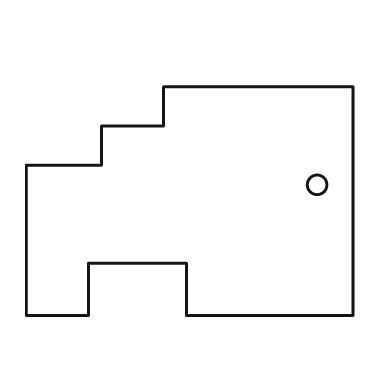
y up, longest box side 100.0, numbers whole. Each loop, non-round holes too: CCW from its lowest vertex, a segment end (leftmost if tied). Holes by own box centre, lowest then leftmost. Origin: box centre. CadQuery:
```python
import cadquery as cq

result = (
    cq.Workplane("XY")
    .moveTo(-50.0, -35.0)
    .lineTo(-31.0, -35.0)
    .lineTo(-31.0, -19.0)
    .lineTo(-1.0, -19.0)
    .lineTo(-1.0, -35.0)
    .lineTo(50.0, -35.0)
    .lineTo(50.0, 35.0)
    .lineTo(-8.0, 35.0)
    .lineTo(-8.0, 23.0)
    .lineTo(-27.0, 23.0)
    .lineTo(-27.0, 11.0)
    .lineTo(-50.0, 11.0)
    .close()
    .moveTo(39.0, 5.0)
    .circle(3.0)
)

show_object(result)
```